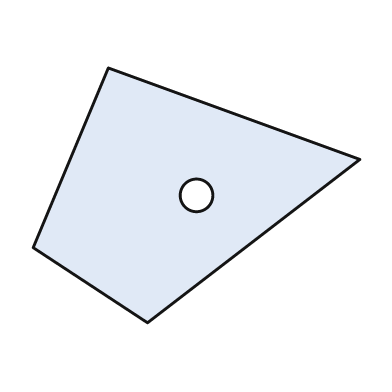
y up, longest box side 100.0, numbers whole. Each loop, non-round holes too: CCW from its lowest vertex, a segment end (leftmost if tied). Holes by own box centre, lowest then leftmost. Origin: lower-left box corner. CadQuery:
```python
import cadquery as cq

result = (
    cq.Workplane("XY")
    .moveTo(35.0, 0.0)
    .lineTo(100.0, 50.0)
    .lineTo(23.0, 78.0)
    .lineTo(0.0, 23.0)
    .close()
    .moveTo(50.0, 39.0)
    .circle(5.0)
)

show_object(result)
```